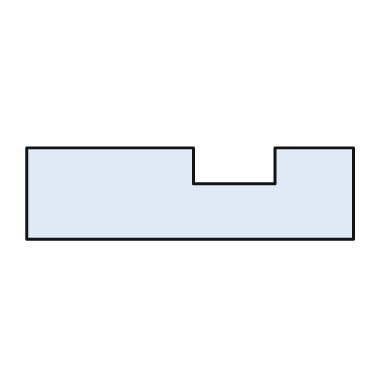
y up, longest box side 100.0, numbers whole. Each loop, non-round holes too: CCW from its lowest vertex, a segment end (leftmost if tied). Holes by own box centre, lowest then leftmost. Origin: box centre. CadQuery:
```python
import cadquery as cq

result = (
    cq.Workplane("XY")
    .moveTo(-50.0, -14.0)
    .lineTo(50.0, -14.0)
    .lineTo(50.0, 14.0)
    .lineTo(26.0, 14.0)
    .lineTo(26.0, 3.0)
    .lineTo(1.0, 3.0)
    .lineTo(1.0, 14.0)
    .lineTo(-50.0, 14.0)
    .close()
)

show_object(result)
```